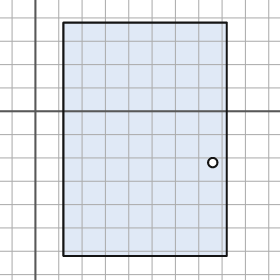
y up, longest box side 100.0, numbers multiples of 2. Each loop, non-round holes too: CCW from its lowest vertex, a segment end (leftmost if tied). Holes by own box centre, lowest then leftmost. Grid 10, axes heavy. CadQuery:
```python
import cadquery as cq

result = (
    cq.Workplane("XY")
    .moveTo(12.0, -62.0)
    .lineTo(82.0, -62.0)
    .lineTo(82.0, 38.0)
    .lineTo(12.0, 38.0)
    .close()
    .moveTo(76.0, -22.0)
    .circle(2.0)
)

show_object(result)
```